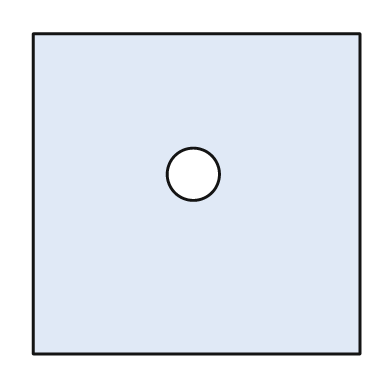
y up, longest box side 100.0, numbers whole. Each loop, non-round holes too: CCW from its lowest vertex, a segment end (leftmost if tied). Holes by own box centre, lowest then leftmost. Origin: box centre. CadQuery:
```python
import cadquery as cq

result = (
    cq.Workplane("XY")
    .moveTo(-50.0, -49.0)
    .lineTo(50.0, -49.0)
    .lineTo(50.0, 49.0)
    .lineTo(-50.0, 49.0)
    .close()
    .moveTo(-1.0, 6.0)
    .circle(8.0)
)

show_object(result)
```